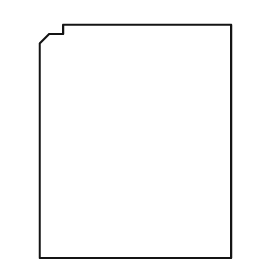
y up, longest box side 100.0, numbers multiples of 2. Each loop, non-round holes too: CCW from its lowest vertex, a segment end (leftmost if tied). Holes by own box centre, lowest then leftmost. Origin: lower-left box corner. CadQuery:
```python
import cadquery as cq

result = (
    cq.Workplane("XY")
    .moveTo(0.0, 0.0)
    .lineTo(82.0, 0.0)
    .lineTo(82.0, 100.0)
    .lineTo(10.0, 100.0)
    .lineTo(10.0, 96.0)
    .lineTo(4.0, 96.0)
    .lineTo(0.0, 92.0)
    .close()
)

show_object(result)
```